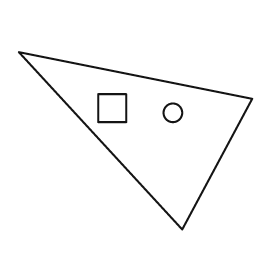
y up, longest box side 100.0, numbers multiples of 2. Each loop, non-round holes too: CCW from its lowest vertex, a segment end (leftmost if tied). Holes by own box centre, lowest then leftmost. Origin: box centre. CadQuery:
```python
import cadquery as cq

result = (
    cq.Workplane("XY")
    .moveTo(20.0, -38.0)
    .lineTo(50.0, 18.0)
    .lineTo(-50.0, 38.0)
    .close()
    .moveTo(16.0, 12.0)
    .circle(4.0)
    .moveTo(-16.0, 8.0)
    .lineTo(-4.0, 8.0)
    .lineTo(-4.0, 20.0)
    .lineTo(-16.0, 20.0)
    .close()
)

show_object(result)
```